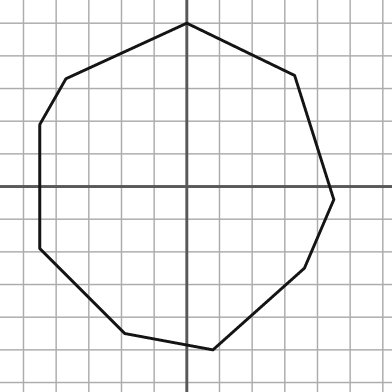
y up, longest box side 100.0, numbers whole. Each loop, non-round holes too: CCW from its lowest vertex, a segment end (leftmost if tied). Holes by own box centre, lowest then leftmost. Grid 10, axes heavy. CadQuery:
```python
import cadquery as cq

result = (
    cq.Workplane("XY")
    .moveTo(8.0, -50.0)
    .lineTo(36.0, -25.0)
    .lineTo(45.0, -4.0)
    .lineTo(33.0, 34.0)
    .lineTo(0.0, 50.0)
    .lineTo(-37.0, 33.0)
    .lineTo(-45.0, 19.0)
    .lineTo(-45.0, -19.0)
    .lineTo(-19.0, -45.0)
    .close()
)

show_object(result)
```